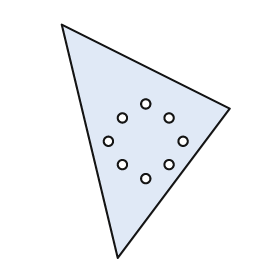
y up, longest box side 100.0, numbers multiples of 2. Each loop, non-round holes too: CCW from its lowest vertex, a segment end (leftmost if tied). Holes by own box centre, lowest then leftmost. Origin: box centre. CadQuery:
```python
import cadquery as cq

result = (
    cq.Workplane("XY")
    .moveTo(-12.0, -50.0)
    .lineTo(36.0, 14.0)
    .lineTo(-36.0, 50.0)
    .close()
    .moveTo(0.0, -16.0)
    .circle(2.0)
    .moveTo(-10.0, -10.0)
    .circle(2.0)
    .moveTo(10.0, -10.0)
    .circle(2.0)
    .moveTo(-16.0, 0.0)
    .circle(2.0)
    .moveTo(16.0, 0.0)
    .circle(2.0)
    .moveTo(-10.0, 10.0)
    .circle(2.0)
    .moveTo(10.0, 10.0)
    .circle(2.0)
    .moveTo(0.0, 16.0)
    .circle(2.0)
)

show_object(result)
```